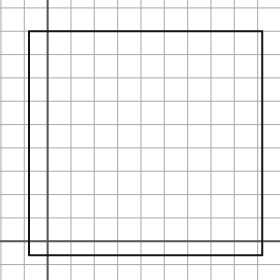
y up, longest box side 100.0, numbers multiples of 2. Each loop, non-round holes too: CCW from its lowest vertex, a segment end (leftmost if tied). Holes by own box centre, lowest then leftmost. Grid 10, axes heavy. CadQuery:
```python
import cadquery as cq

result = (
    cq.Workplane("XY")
    .moveTo(-8.0, -6.0)
    .lineTo(92.0, -6.0)
    .lineTo(92.0, 90.0)
    .lineTo(-8.0, 90.0)
    .close()
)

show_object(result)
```